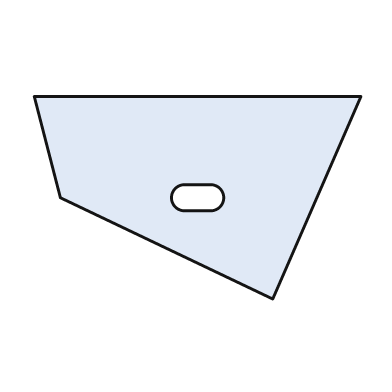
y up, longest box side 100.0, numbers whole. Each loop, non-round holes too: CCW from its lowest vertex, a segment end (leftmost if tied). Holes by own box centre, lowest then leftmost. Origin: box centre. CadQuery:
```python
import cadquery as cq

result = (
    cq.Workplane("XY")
    .moveTo(23.0, -31.0)
    .lineTo(50.0, 31.0)
    .lineTo(-50.0, 31.0)
    .lineTo(-42.0, 0.0)
    .close()
    .moveTo(-4.0, -4.0)
    .lineTo(4.0, -4.0)
    .threePointArc((8.0, 0.0), (4.0, 4.0))
    .lineTo(-4.0, 4.0)
    .threePointArc((-8.0, 0.0), (-4.0, -4.0))
    .close()
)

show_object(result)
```